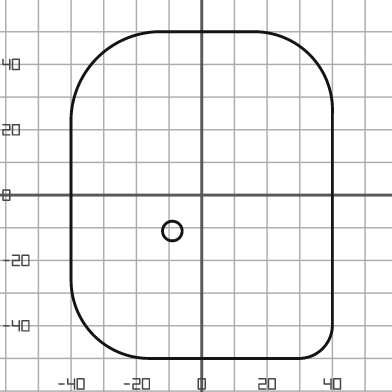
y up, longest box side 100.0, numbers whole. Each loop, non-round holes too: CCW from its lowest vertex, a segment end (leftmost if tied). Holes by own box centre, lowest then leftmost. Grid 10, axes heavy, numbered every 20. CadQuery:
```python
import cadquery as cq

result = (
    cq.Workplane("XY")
    .moveTo(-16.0, -50.0)
    .lineTo(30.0, -50.0)
    .threePointArc((37.0, -47.0), (40.0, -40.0))
    .lineTo(40.0, 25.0)
    .threePointArc((33.0, 43.0), (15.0, 50.0))
    .lineTo(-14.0, 50.0)
    .threePointArc((-32.0, 42.0), (-40.0, 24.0))
    .lineTo(-40.0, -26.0)
    .threePointArc((-33.0, -43.0), (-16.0, -50.0))
    .close()
    .moveTo(-9.0, -11.0)
    .circle(3.0)
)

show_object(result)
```